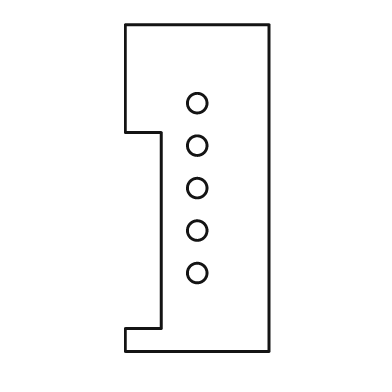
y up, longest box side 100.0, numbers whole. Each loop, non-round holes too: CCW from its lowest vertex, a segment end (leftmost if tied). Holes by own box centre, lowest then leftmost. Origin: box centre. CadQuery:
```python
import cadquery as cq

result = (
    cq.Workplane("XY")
    .moveTo(-22.0, -50.0)
    .lineTo(22.0, -50.0)
    .lineTo(22.0, 50.0)
    .lineTo(-22.0, 50.0)
    .lineTo(-22.0, 17.0)
    .lineTo(-11.0, 17.0)
    .lineTo(-11.0, -43.0)
    .lineTo(-22.0, -43.0)
    .close()
    .moveTo(0.0, -26.0)
    .circle(3.0)
    .moveTo(0.0, -13.0)
    .circle(3.0)
    .moveTo(0.0, 0.0)
    .circle(3.0)
    .moveTo(0.0, 13.0)
    .circle(3.0)
    .moveTo(0.0, 26.0)
    .circle(3.0)
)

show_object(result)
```